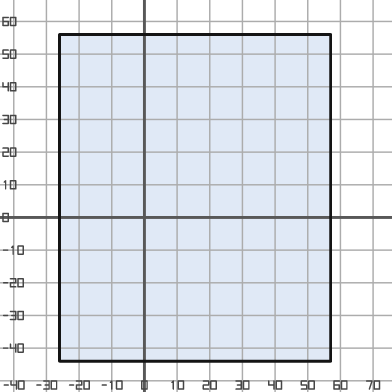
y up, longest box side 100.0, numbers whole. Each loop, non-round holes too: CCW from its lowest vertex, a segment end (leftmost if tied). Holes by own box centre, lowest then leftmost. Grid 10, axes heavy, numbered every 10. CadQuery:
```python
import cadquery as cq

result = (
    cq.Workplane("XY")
    .moveTo(-26.0, -44.0)
    .lineTo(57.0, -44.0)
    .lineTo(57.0, 56.0)
    .lineTo(-26.0, 56.0)
    .close()
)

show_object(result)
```